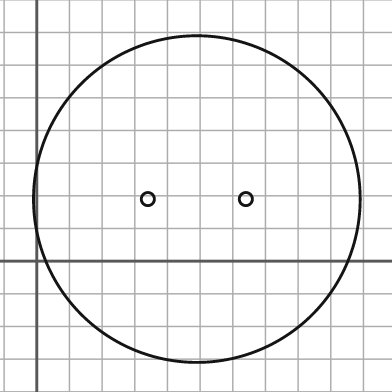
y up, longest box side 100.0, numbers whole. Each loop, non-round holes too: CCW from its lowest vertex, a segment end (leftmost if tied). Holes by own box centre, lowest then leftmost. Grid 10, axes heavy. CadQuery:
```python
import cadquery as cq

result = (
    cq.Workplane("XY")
    .moveTo(49.0, 19.0)
    .circle(50.0)
    .moveTo(34.0, 19.0)
    .circle(2.0)
    .moveTo(64.0, 19.0)
    .circle(2.0)
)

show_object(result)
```